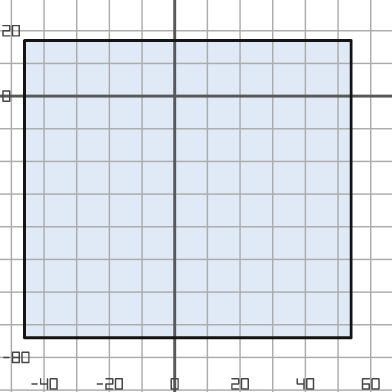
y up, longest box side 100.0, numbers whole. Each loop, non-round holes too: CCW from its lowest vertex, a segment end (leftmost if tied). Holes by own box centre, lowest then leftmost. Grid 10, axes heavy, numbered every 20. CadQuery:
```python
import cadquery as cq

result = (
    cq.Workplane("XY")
    .moveTo(-46.0, -74.0)
    .lineTo(54.0, -74.0)
    .lineTo(54.0, 17.0)
    .lineTo(-46.0, 17.0)
    .close()
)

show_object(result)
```